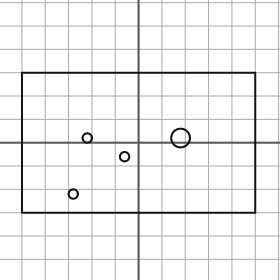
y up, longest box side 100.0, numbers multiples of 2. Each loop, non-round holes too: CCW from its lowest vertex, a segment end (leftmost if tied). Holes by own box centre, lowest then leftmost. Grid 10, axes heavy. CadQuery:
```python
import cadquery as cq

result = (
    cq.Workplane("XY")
    .moveTo(-50.0, -30.0)
    .lineTo(50.0, -30.0)
    .lineTo(50.0, 30.0)
    .lineTo(-50.0, 30.0)
    .close()
    .moveTo(-28.0, -22.0)
    .circle(2.0)
    .moveTo(-6.0, -6.0)
    .circle(2.0)
    .moveTo(-22.0, 2.0)
    .circle(2.0)
    .moveTo(18.0, 2.0)
    .circle(4.0)
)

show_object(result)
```